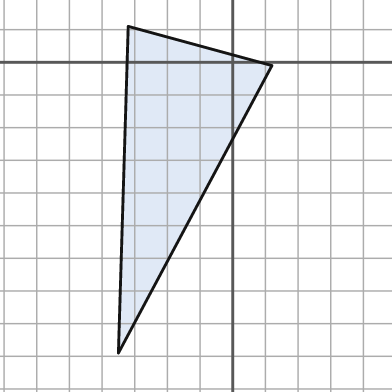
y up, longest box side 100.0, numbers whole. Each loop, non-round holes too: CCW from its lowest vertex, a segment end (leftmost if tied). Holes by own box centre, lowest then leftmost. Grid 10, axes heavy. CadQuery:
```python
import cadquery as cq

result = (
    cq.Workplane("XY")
    .moveTo(-35.0, -89.0)
    .lineTo(12.0, -1.0)
    .lineTo(-32.0, 11.0)
    .close()
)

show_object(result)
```